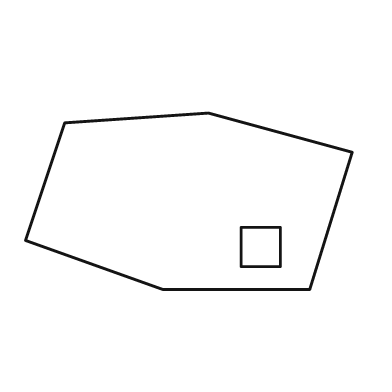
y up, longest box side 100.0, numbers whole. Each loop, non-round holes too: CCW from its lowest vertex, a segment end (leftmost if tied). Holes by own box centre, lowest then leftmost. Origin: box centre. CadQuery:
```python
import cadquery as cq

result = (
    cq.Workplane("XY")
    .moveTo(-8.0, -27.0)
    .lineTo(37.0, -27.0)
    .lineTo(50.0, 15.0)
    .lineTo(6.0, 27.0)
    .lineTo(-38.0, 24.0)
    .lineTo(-50.0, -12.0)
    .close()
    .moveTo(16.0, -20.0)
    .lineTo(28.0, -20.0)
    .lineTo(28.0, -8.0)
    .lineTo(16.0, -8.0)
    .close()
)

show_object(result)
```